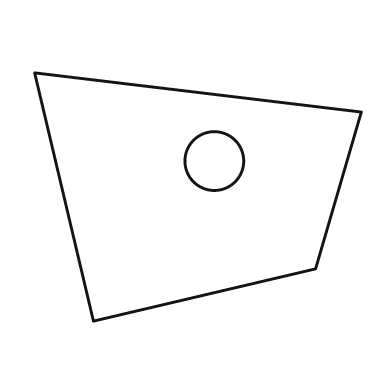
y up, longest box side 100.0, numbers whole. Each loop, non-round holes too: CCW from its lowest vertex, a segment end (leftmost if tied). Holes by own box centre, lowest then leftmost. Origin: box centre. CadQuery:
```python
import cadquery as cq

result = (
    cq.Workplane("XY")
    .moveTo(-32.0, -38.0)
    .lineTo(36.0, -22.0)
    .lineTo(50.0, 26.0)
    .lineTo(-50.0, 38.0)
    .close()
    .moveTo(5.0, 11.0)
    .circle(9.0)
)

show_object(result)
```